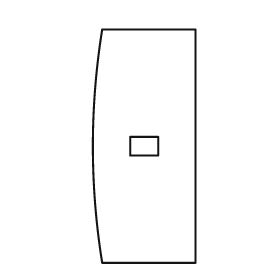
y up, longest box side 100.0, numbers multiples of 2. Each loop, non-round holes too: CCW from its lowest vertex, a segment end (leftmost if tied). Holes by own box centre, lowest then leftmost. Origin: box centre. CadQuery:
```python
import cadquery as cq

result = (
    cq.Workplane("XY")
    .moveTo(-18.0, -50.0)
    .lineTo(22.0, -50.0)
    .lineTo(22.0, 50.0)
    .lineTo(-18.0, 50.0)
    .threePointArc((-22.0, 0.0), (-18.0, -50.0))
    .close()
    .moveTo(-6.0, -4.0)
    .lineTo(6.0, -4.0)
    .lineTo(6.0, 4.0)
    .lineTo(-6.0, 4.0)
    .close()
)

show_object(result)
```